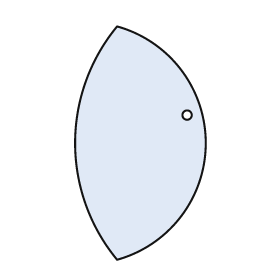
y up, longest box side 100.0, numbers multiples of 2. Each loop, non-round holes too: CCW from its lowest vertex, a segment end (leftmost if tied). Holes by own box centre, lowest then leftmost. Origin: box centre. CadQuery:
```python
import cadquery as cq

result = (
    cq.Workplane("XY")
    .moveTo(-10.0, -50.0)
    .threePointArc((28.0, 0.0), (-10.0, 50.0))
    .threePointArc((-28.0, 0.0), (-10.0, -50.0))
    .close()
    .moveTo(20.0, 12.0)
    .circle(2.0)
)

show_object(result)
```